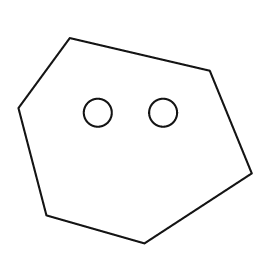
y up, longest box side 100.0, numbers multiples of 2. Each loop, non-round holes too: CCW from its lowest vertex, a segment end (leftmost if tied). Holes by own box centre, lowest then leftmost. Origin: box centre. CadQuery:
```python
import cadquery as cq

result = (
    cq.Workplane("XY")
    .moveTo(4.0, -44.0)
    .lineTo(50.0, -14.0)
    .lineTo(32.0, 30.0)
    .lineTo(-28.0, 44.0)
    .lineTo(-50.0, 14.0)
    .lineTo(-38.0, -32.0)
    .close()
    .moveTo(-16.0, 12.0)
    .circle(6.0)
    .moveTo(12.0, 12.0)
    .circle(6.0)
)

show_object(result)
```